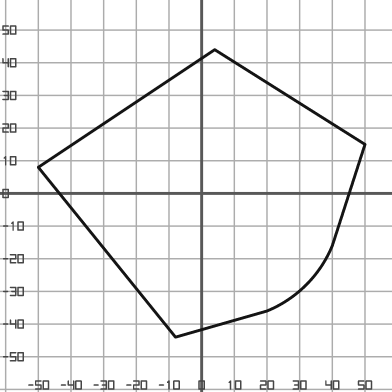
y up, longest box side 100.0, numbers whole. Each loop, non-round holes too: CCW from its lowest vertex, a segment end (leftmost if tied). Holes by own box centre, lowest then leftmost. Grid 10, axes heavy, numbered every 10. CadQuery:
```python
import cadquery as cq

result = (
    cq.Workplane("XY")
    .moveTo(-8.0, -44.0)
    .lineTo(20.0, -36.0)
    .threePointArc((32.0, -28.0), (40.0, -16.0))
    .lineTo(50.0, 15.0)
    .lineTo(4.0, 44.0)
    .lineTo(-50.0, 8.0)
    .close()
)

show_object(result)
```